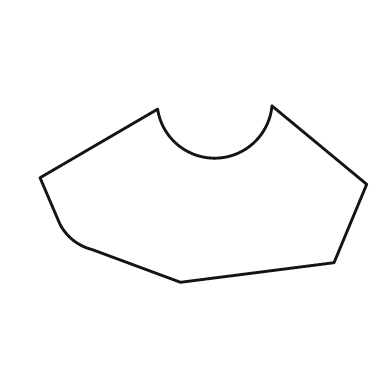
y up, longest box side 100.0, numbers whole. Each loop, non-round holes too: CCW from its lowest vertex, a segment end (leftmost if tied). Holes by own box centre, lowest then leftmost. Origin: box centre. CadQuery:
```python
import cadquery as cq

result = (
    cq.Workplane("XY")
    .moveTo(-7.0, -27.0)
    .lineTo(40.0, -21.0)
    .lineTo(50.0, 3.0)
    .lineTo(21.0, 27.0)
    .threePointArc((4.0, 11.0), (-14.0, 26.0))
    .lineTo(-50.0, 5.0)
    .lineTo(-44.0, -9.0)
    .threePointArc((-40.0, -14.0), (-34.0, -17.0))
    .close()
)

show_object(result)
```